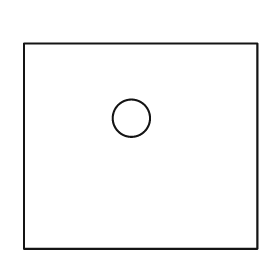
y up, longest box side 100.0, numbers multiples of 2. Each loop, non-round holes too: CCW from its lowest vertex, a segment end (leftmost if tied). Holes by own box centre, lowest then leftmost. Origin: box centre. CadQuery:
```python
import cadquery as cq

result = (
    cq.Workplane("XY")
    .moveTo(-50.0, -44.0)
    .lineTo(50.0, -44.0)
    .lineTo(50.0, 44.0)
    .lineTo(-50.0, 44.0)
    .close()
    .moveTo(-4.0, 12.0)
    .circle(8.0)
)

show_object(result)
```